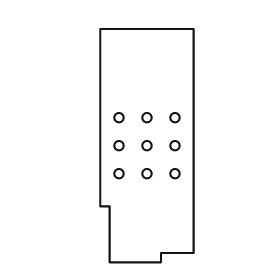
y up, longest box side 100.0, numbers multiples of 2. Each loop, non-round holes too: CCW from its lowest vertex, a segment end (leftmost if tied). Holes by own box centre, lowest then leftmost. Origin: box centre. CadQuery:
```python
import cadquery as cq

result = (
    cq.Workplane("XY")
    .moveTo(-16.0, -50.0)
    .lineTo(6.0, -50.0)
    .lineTo(6.0, -46.0)
    .lineTo(20.0, -46.0)
    .lineTo(20.0, 50.0)
    .lineTo(-20.0, 50.0)
    .lineTo(-20.0, -26.0)
    .lineTo(-16.0, -26.0)
    .close()
    .moveTo(-12.0, -12.0)
    .circle(2.0)
    .moveTo(0.0, -12.0)
    .circle(2.0)
    .moveTo(12.0, -12.0)
    .circle(2.0)
    .moveTo(-12.0, 0.0)
    .circle(2.0)
    .moveTo(0.0, 0.0)
    .circle(2.0)
    .moveTo(12.0, 0.0)
    .circle(2.0)
    .moveTo(-12.0, 12.0)
    .circle(2.0)
    .moveTo(0.0, 12.0)
    .circle(2.0)
    .moveTo(12.0, 12.0)
    .circle(2.0)
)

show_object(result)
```